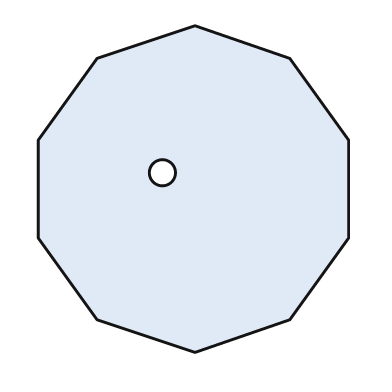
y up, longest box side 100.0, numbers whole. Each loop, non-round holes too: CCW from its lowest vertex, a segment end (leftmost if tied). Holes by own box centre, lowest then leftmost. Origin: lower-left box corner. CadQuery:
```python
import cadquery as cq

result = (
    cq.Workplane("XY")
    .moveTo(48.0, 0.0)
    .lineTo(77.0, 10.0)
    .lineTo(95.0, 35.0)
    .lineTo(95.0, 65.0)
    .lineTo(77.0, 90.0)
    .lineTo(48.0, 100.0)
    .lineTo(18.0, 90.0)
    .lineTo(0.0, 65.0)
    .lineTo(0.0, 35.0)
    .lineTo(18.0, 10.0)
    .close()
    .moveTo(38.0, 55.0)
    .circle(4.0)
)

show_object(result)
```